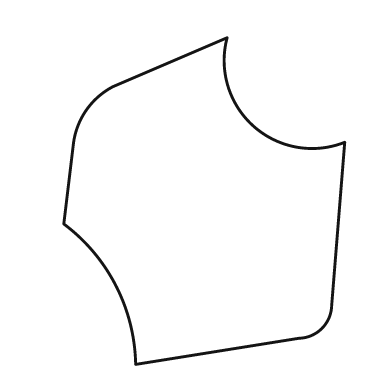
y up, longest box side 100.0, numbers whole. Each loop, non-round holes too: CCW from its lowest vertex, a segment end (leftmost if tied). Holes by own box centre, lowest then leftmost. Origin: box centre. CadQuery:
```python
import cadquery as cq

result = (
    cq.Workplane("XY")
    .moveTo(-21.0, -50.0)
    .lineTo(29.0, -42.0)
    .threePointArc((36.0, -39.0), (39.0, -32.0))
    .lineTo(43.0, 18.0)
    .threePointArc((15.0, 23.0), (7.0, 50.0))
    .lineTo(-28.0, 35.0)
    .threePointArc((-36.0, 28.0), (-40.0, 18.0))
    .lineTo(-43.0, -7.0)
    .threePointArc((-27.0, -26.0), (-21.0, -50.0))
    .close()
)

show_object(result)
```